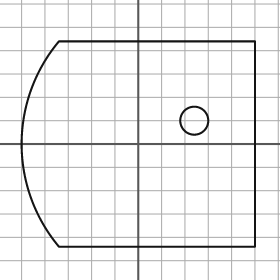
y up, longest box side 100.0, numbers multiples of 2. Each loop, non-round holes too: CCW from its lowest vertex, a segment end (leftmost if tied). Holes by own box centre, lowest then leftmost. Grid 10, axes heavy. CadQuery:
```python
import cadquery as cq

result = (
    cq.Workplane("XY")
    .moveTo(-34.0, -44.0)
    .lineTo(50.0, -44.0)
    .lineTo(50.0, 44.0)
    .lineTo(-34.0, 44.0)
    .threePointArc((-50.0, 0.0), (-34.0, -44.0))
    .close()
    .moveTo(24.0, 10.0)
    .circle(6.0)
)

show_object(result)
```